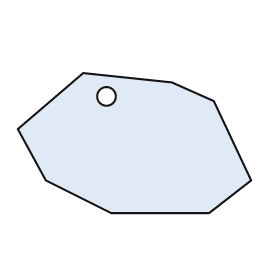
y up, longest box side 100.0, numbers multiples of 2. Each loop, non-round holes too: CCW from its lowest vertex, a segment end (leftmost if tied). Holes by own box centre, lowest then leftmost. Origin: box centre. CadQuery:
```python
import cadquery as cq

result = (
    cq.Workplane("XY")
    .moveTo(-10.0, -30.0)
    .lineTo(32.0, -30.0)
    .lineTo(50.0, -16.0)
    .lineTo(34.0, 18.0)
    .lineTo(16.0, 26.0)
    .lineTo(-22.0, 30.0)
    .lineTo(-50.0, 6.0)
    .lineTo(-38.0, -16.0)
    .close()
    .moveTo(-12.0, 20.0)
    .circle(4.0)
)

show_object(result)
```